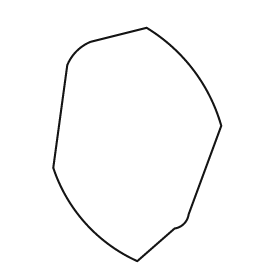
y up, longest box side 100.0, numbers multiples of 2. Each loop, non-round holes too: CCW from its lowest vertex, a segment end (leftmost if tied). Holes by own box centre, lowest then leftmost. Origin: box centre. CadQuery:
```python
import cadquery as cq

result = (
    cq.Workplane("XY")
    .moveTo(0.0, -50.0)
    .lineTo(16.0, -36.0)
    .threePointArc((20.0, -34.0), (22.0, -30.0))
    .lineTo(36.0, 8.0)
    .threePointArc((24.0, 32.0), (4.0, 50.0))
    .lineTo(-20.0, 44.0)
    .threePointArc((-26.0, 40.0), (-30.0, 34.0))
    .lineTo(-36.0, -10.0)
    .threePointArc((-22.0, -34.0), (0.0, -50.0))
    .close()
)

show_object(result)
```